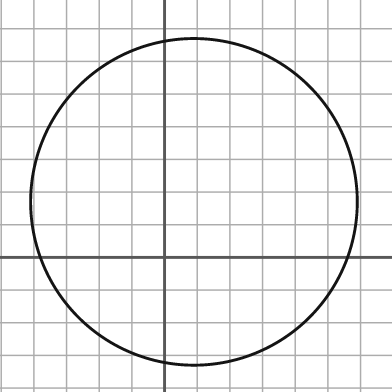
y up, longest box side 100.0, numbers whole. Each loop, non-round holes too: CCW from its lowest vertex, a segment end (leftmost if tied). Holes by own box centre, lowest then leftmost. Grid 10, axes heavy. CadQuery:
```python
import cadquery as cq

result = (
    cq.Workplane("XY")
    .moveTo(9.0, 17.0)
    .circle(50.0)
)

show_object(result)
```